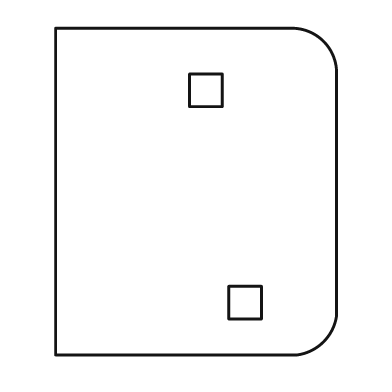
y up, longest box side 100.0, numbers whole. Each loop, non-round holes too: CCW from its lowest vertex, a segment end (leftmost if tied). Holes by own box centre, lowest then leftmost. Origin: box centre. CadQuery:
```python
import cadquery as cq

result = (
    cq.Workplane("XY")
    .moveTo(-43.0, -50.0)
    .lineTo(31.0, -50.0)
    .threePointArc((39.0, -46.0), (43.0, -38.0))
    .lineTo(43.0, 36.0)
    .threePointArc((39.0, 46.0), (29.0, 50.0))
    .lineTo(-43.0, 50.0)
    .close()
    .moveTo(10.0, -39.0)
    .lineTo(20.0, -39.0)
    .lineTo(20.0, -29.0)
    .lineTo(10.0, -29.0)
    .close()
    .moveTo(-2.0, 26.0)
    .lineTo(8.0, 26.0)
    .lineTo(8.0, 36.0)
    .lineTo(-2.0, 36.0)
    .close()
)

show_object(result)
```